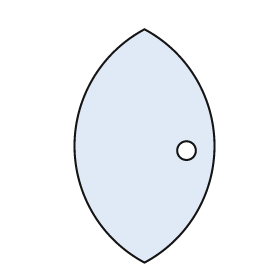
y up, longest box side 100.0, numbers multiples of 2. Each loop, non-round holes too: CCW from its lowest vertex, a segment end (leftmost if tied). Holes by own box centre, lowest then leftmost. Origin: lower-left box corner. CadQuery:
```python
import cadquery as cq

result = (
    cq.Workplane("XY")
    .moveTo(30.0, 0.0)
    .threePointArc((60.0, 50.0), (30.0, 100.0))
    .threePointArc((0.0, 50.0), (30.0, 0.0))
    .close()
    .moveTo(48.0, 48.0)
    .circle(4.0)
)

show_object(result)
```